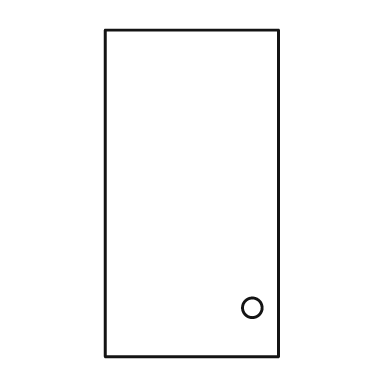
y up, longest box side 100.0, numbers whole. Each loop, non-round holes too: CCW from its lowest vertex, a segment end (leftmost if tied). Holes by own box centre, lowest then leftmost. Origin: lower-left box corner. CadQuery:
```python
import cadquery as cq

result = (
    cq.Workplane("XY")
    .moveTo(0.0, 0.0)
    .lineTo(53.0, 0.0)
    .lineTo(53.0, 100.0)
    .lineTo(0.0, 100.0)
    .close()
    .moveTo(45.0, 15.0)
    .circle(3.0)
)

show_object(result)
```